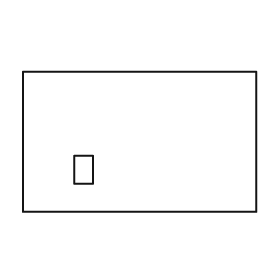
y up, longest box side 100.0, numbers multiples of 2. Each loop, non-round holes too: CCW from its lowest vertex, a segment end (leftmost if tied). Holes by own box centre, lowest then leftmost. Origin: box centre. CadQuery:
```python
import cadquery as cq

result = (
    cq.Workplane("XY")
    .moveTo(-50.0, -30.0)
    .lineTo(50.0, -30.0)
    .lineTo(50.0, 30.0)
    .lineTo(-50.0, 30.0)
    .close()
    .moveTo(-28.0, -18.0)
    .lineTo(-20.0, -18.0)
    .lineTo(-20.0, -6.0)
    .lineTo(-28.0, -6.0)
    .close()
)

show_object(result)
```